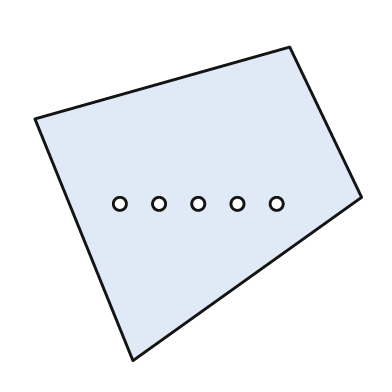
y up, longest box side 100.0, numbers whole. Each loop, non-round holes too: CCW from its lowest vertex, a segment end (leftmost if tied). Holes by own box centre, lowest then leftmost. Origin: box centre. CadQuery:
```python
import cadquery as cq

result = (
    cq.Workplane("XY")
    .moveTo(-20.0, -48.0)
    .lineTo(50.0, 2.0)
    .lineTo(28.0, 48.0)
    .lineTo(-50.0, 26.0)
    .close()
    .moveTo(-24.0, 0.0)
    .circle(2.0)
    .moveTo(-12.0, 0.0)
    .circle(2.0)
    .moveTo(0.0, 0.0)
    .circle(2.0)
    .moveTo(12.0, 0.0)
    .circle(2.0)
    .moveTo(24.0, 0.0)
    .circle(2.0)
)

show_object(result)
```